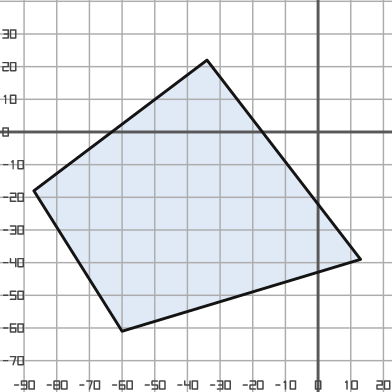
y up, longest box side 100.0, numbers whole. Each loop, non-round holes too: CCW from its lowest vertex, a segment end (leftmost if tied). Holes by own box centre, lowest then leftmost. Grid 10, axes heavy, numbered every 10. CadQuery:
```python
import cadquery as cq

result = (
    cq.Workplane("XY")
    .moveTo(-60.0, -61.0)
    .lineTo(13.0, -39.0)
    .lineTo(-34.0, 22.0)
    .lineTo(-87.0, -18.0)
    .close()
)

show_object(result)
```